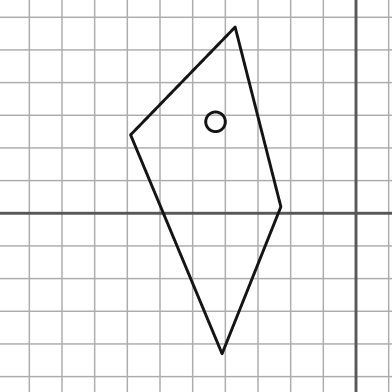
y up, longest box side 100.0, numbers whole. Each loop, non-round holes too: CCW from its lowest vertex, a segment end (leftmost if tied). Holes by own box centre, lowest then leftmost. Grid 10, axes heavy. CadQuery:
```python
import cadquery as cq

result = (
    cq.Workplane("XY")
    .moveTo(-41.0, -43.0)
    .lineTo(-23.0, 2.0)
    .lineTo(-37.0, 57.0)
    .lineTo(-69.0, 24.0)
    .close()
    .moveTo(-43.0, 28.0)
    .circle(3.0)
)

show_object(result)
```